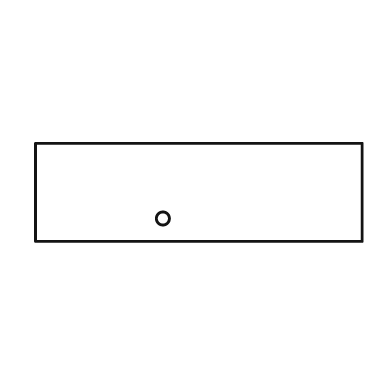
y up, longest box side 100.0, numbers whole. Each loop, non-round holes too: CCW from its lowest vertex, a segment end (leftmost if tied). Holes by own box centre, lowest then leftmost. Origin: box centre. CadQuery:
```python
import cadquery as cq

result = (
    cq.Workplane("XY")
    .moveTo(-50.0, -15.0)
    .lineTo(50.0, -15.0)
    .lineTo(50.0, 15.0)
    .lineTo(-50.0, 15.0)
    .close()
    .moveTo(-11.0, -8.0)
    .circle(2.0)
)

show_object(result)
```